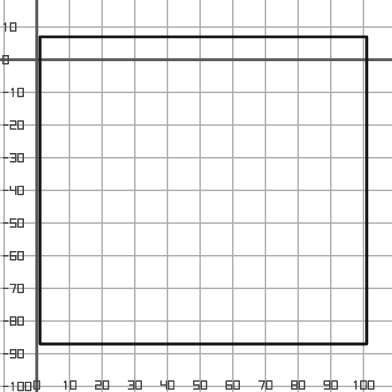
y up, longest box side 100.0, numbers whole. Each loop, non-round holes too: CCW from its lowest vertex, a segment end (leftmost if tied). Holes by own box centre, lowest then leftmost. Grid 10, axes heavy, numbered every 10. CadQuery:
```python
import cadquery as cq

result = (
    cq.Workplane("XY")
    .moveTo(1.0, -87.0)
    .lineTo(101.0, -87.0)
    .lineTo(101.0, 7.0)
    .lineTo(1.0, 7.0)
    .close()
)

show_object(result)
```